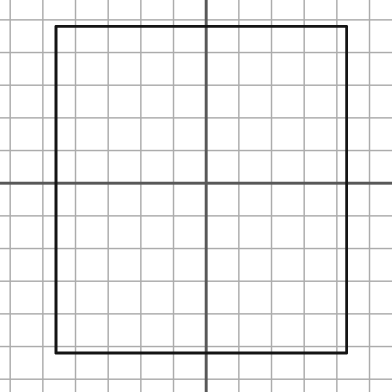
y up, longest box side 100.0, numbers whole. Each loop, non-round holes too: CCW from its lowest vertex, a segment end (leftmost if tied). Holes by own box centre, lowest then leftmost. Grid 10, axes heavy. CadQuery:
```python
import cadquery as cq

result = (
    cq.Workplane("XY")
    .moveTo(-46.0, -52.0)
    .lineTo(43.0, -52.0)
    .lineTo(43.0, 48.0)
    .lineTo(-46.0, 48.0)
    .close()
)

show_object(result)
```